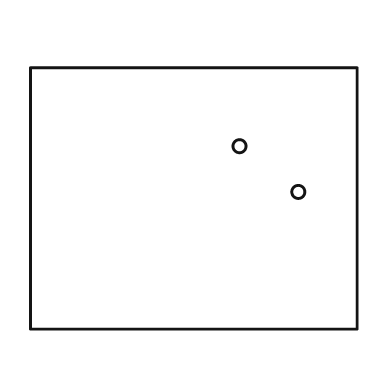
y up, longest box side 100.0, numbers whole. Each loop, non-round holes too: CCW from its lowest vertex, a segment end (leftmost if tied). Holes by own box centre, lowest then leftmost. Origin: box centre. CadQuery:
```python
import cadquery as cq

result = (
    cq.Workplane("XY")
    .moveTo(-50.0, -40.0)
    .lineTo(50.0, -40.0)
    .lineTo(50.0, 40.0)
    .lineTo(-50.0, 40.0)
    .close()
    .moveTo(32.0, 2.0)
    .circle(2.0)
    .moveTo(14.0, 16.0)
    .circle(2.0)
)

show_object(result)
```